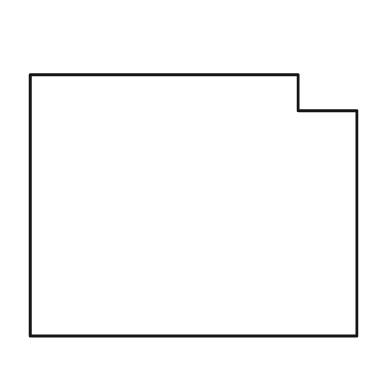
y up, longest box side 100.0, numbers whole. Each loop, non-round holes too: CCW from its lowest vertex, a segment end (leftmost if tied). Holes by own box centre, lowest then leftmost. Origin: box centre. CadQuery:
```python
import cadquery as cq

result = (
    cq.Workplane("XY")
    .moveTo(-50.0, -40.0)
    .lineTo(50.0, -40.0)
    .lineTo(50.0, 29.0)
    .lineTo(32.0, 29.0)
    .lineTo(32.0, 40.0)
    .lineTo(-50.0, 40.0)
    .close()
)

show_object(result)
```